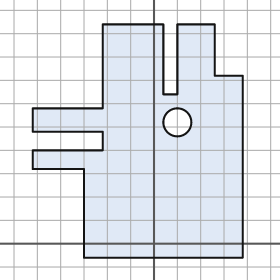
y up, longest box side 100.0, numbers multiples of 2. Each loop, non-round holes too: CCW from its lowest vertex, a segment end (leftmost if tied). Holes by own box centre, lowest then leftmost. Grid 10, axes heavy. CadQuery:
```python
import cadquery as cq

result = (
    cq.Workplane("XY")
    .moveTo(-30.0, -6.0)
    .lineTo(38.0, -6.0)
    .lineTo(38.0, 72.0)
    .lineTo(26.0, 72.0)
    .lineTo(26.0, 94.0)
    .lineTo(10.0, 94.0)
    .lineTo(10.0, 64.0)
    .lineTo(4.0, 64.0)
    .lineTo(4.0, 94.0)
    .lineTo(-22.0, 94.0)
    .lineTo(-22.0, 58.0)
    .lineTo(-52.0, 58.0)
    .lineTo(-52.0, 48.0)
    .lineTo(-22.0, 48.0)
    .lineTo(-22.0, 40.0)
    .lineTo(-52.0, 40.0)
    .lineTo(-52.0, 32.0)
    .lineTo(-30.0, 32.0)
    .close()
    .moveTo(10.0, 52.0)
    .circle(6.0)
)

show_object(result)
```